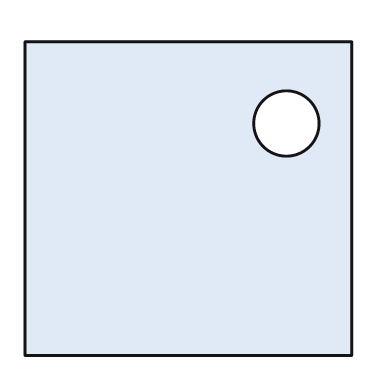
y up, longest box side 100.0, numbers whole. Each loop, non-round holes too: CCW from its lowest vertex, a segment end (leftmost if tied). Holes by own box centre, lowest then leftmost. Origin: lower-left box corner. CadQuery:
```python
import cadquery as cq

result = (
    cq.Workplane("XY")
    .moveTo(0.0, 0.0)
    .lineTo(100.0, 0.0)
    .lineTo(100.0, 96.0)
    .lineTo(0.0, 96.0)
    .close()
    .moveTo(80.0, 71.0)
    .circle(10.0)
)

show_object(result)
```